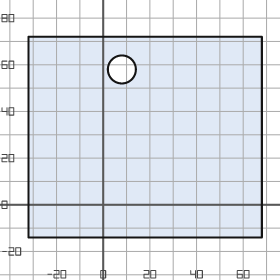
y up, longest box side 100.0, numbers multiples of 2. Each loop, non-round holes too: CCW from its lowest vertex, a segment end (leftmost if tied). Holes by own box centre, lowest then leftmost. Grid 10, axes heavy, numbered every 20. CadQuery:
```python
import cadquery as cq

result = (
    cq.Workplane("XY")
    .moveTo(-32.0, -14.0)
    .lineTo(68.0, -14.0)
    .lineTo(68.0, 72.0)
    .lineTo(-32.0, 72.0)
    .close()
    .moveTo(8.0, 58.0)
    .circle(6.0)
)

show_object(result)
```